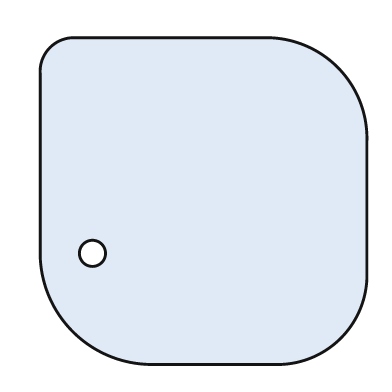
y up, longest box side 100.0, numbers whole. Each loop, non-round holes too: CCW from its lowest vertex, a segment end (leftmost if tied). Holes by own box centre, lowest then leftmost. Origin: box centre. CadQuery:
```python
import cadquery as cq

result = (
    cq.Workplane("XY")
    .moveTo(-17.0, -50.0)
    .lineTo(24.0, -50.0)
    .threePointArc((42.0, -42.0), (50.0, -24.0))
    .lineTo(50.0, 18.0)
    .threePointArc((41.0, 41.0), (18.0, 50.0))
    .lineTo(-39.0, 50.0)
    .threePointArc((-47.0, 47.0), (-50.0, 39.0))
    .lineTo(-50.0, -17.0)
    .threePointArc((-40.0, -40.0), (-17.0, -50.0))
    .close()
    .moveTo(-34.0, -16.0)
    .circle(4.0)
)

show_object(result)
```